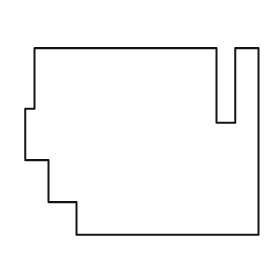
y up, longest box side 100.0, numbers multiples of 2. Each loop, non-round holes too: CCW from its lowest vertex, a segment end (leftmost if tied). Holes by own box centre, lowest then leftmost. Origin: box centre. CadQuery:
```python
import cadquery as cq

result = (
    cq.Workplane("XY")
    .moveTo(-28.0, -40.0)
    .lineTo(50.0, -40.0)
    .lineTo(50.0, 40.0)
    .lineTo(40.0, 40.0)
    .lineTo(40.0, 8.0)
    .lineTo(32.0, 8.0)
    .lineTo(32.0, 40.0)
    .lineTo(-46.0, 40.0)
    .lineTo(-46.0, 14.0)
    .lineTo(-50.0, 14.0)
    .lineTo(-50.0, -8.0)
    .lineTo(-40.0, -8.0)
    .lineTo(-40.0, -26.0)
    .lineTo(-28.0, -26.0)
    .close()
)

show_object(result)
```